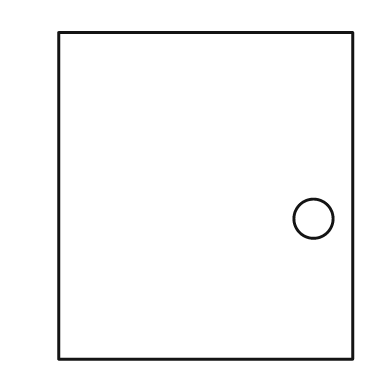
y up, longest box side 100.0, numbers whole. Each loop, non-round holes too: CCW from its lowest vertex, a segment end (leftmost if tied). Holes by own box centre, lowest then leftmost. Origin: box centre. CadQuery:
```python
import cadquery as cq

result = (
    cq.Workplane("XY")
    .moveTo(-45.0, -50.0)
    .lineTo(45.0, -50.0)
    .lineTo(45.0, 50.0)
    .lineTo(-45.0, 50.0)
    .close()
    .moveTo(33.0, -7.0)
    .circle(6.0)
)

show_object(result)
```